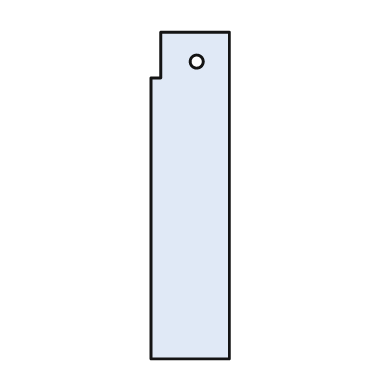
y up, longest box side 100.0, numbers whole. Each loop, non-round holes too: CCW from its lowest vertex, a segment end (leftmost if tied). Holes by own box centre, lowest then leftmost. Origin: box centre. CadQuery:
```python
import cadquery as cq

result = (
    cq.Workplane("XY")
    .moveTo(-12.0, -50.0)
    .lineTo(12.0, -50.0)
    .lineTo(12.0, 50.0)
    .lineTo(-9.0, 50.0)
    .lineTo(-9.0, 36.0)
    .lineTo(-12.0, 36.0)
    .close()
    .moveTo(2.0, 41.0)
    .circle(2.0)
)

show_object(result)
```